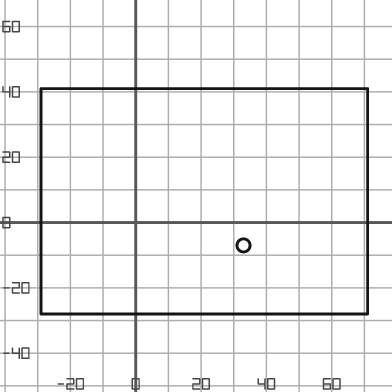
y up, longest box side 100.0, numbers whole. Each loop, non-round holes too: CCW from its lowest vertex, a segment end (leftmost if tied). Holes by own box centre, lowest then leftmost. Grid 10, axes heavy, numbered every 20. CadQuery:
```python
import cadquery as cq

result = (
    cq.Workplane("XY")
    .moveTo(-29.0, -28.0)
    .lineTo(71.0, -28.0)
    .lineTo(71.0, 41.0)
    .lineTo(-29.0, 41.0)
    .close()
    .moveTo(33.0, -7.0)
    .circle(2.0)
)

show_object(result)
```